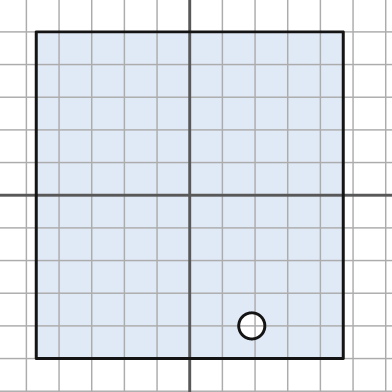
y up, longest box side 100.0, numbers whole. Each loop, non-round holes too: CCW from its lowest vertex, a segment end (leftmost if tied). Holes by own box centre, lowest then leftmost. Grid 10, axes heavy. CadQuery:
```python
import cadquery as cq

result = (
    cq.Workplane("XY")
    .moveTo(-47.0, -50.0)
    .lineTo(47.0, -50.0)
    .lineTo(47.0, 50.0)
    .lineTo(-47.0, 50.0)
    .close()
    .moveTo(19.0, -40.0)
    .circle(4.0)
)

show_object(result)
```